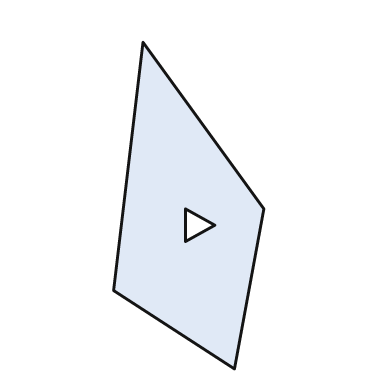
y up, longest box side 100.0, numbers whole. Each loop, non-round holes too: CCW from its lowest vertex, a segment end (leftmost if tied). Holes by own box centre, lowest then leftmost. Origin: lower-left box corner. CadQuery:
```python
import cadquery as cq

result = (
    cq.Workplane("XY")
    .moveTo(37.0, 0.0)
    .lineTo(46.0, 49.0)
    .lineTo(9.0, 100.0)
    .lineTo(0.0, 24.0)
    .close()
    .moveTo(22.0, 39.0)
    .lineTo(31.0, 44.0)
    .lineTo(22.0, 49.0)
    .close()
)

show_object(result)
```